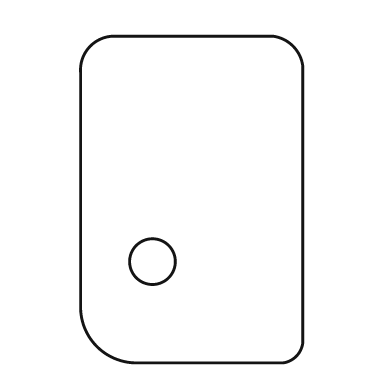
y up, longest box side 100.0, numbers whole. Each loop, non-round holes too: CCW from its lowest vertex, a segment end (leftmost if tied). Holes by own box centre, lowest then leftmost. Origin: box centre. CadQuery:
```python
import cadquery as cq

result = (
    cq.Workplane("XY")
    .moveTo(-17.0, -50.0)
    .lineTo(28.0, -50.0)
    .threePointArc((32.0, -48.0), (34.0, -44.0))
    .lineTo(34.0, 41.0)
    .threePointArc((31.0, 47.0), (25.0, 50.0))
    .lineTo(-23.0, 50.0)
    .threePointArc((-31.0, 47.0), (-34.0, 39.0))
    .lineTo(-34.0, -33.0)
    .threePointArc((-29.0, -45.0), (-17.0, -50.0))
    .close()
    .moveTo(-12.0, -19.0)
    .circle(7.0)
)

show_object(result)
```